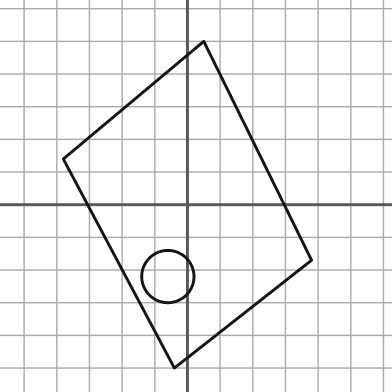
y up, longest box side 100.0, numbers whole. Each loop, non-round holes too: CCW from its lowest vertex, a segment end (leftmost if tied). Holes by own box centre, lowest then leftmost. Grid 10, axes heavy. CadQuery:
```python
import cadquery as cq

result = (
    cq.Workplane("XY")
    .moveTo(-4.0, -50.0)
    .lineTo(38.0, -17.0)
    .lineTo(5.0, 50.0)
    .lineTo(-38.0, 14.0)
    .close()
    .moveTo(-6.0, -22.0)
    .circle(8.0)
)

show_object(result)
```